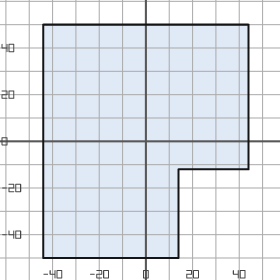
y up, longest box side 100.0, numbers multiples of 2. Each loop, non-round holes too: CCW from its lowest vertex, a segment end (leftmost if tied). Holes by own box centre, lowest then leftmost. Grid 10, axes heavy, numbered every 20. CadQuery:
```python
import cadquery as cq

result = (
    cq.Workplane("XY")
    .moveTo(-44.0, -50.0)
    .lineTo(14.0, -50.0)
    .lineTo(14.0, -12.0)
    .lineTo(44.0, -12.0)
    .lineTo(44.0, 50.0)
    .lineTo(-44.0, 50.0)
    .close()
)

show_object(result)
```